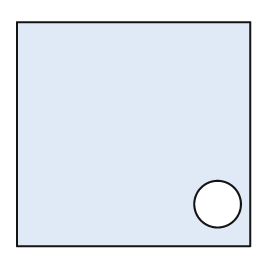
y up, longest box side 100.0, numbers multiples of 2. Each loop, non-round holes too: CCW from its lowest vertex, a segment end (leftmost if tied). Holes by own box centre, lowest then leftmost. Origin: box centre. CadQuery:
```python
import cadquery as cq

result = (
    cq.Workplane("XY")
    .moveTo(-50.0, -48.0)
    .lineTo(50.0, -48.0)
    .lineTo(50.0, 48.0)
    .lineTo(-50.0, 48.0)
    .close()
    .moveTo(36.0, -30.0)
    .circle(10.0)
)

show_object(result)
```